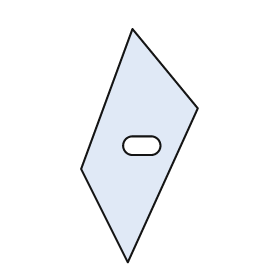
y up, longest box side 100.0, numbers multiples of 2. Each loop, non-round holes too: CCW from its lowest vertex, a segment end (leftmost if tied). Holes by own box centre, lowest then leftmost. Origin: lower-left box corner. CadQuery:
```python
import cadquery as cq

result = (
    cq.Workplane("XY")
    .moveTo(20.0, 0.0)
    .lineTo(50.0, 66.0)
    .lineTo(22.0, 100.0)
    .lineTo(0.0, 40.0)
    .close()
    .moveTo(22.0, 46.0)
    .lineTo(30.0, 46.0)
    .threePointArc((34.0, 50.0), (30.0, 54.0))
    .lineTo(22.0, 54.0)
    .threePointArc((18.0, 50.0), (22.0, 46.0))
    .close()
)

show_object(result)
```